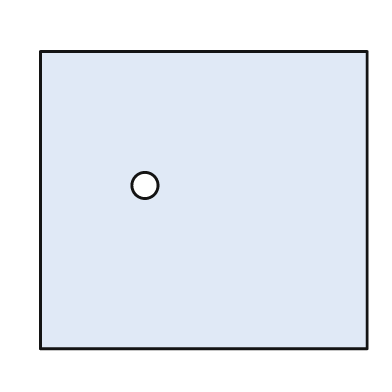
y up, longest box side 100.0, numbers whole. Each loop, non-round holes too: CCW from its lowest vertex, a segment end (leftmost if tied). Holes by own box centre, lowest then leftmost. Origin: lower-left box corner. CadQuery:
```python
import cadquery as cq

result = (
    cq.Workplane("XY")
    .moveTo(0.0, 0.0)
    .lineTo(100.0, 0.0)
    .lineTo(100.0, 91.0)
    .lineTo(0.0, 91.0)
    .close()
    .moveTo(32.0, 50.0)
    .circle(4.0)
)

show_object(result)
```